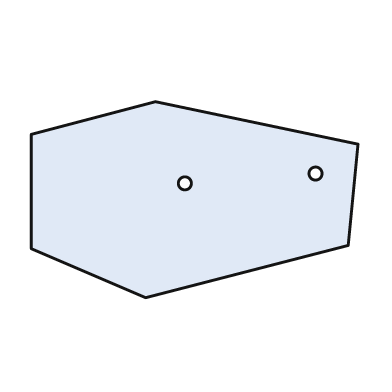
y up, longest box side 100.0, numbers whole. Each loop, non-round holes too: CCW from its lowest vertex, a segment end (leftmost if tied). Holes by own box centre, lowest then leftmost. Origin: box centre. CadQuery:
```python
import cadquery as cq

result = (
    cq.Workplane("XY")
    .moveTo(-15.0, -30.0)
    .lineTo(47.0, -14.0)
    .lineTo(50.0, 17.0)
    .lineTo(-12.0, 30.0)
    .lineTo(-50.0, 20.0)
    .lineTo(-50.0, -15.0)
    .close()
    .moveTo(-3.0, 5.0)
    .circle(2.0)
    .moveTo(37.0, 8.0)
    .circle(2.0)
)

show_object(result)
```